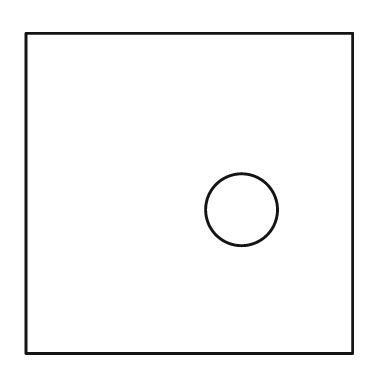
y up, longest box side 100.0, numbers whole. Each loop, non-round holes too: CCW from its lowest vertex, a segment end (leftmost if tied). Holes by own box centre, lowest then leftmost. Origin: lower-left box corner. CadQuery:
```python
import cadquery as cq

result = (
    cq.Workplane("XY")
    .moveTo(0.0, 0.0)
    .lineTo(100.0, 0.0)
    .lineTo(100.0, 98.0)
    .lineTo(0.0, 98.0)
    .close()
    .moveTo(66.0, 44.0)
    .circle(11.0)
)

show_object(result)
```